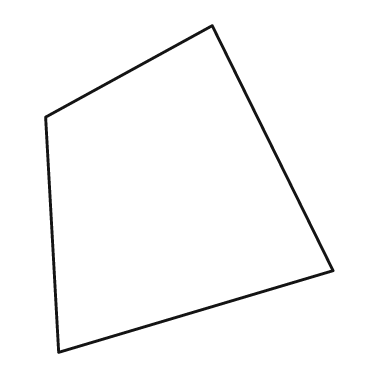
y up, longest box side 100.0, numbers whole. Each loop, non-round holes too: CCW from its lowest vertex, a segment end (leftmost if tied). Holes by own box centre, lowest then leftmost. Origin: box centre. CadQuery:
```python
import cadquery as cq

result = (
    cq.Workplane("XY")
    .moveTo(-40.0, -50.0)
    .lineTo(44.0, -25.0)
    .lineTo(7.0, 50.0)
    .lineTo(-44.0, 22.0)
    .close()
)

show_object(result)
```